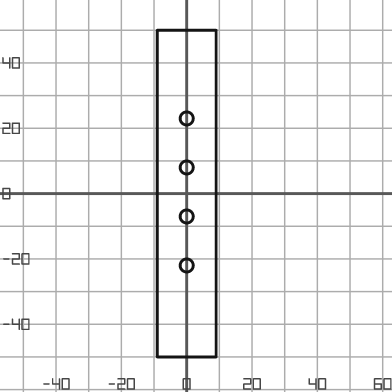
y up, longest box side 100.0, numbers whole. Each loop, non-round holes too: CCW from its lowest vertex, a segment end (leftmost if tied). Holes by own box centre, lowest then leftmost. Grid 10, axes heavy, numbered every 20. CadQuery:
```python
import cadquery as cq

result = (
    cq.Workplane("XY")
    .moveTo(-9.0, -50.0)
    .lineTo(9.0, -50.0)
    .lineTo(9.0, 50.0)
    .lineTo(-9.0, 50.0)
    .close()
    .moveTo(0.0, -22.0)
    .circle(2.0)
    .moveTo(0.0, -7.0)
    .circle(2.0)
    .moveTo(0.0, 8.0)
    .circle(2.0)
    .moveTo(0.0, 23.0)
    .circle(2.0)
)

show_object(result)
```